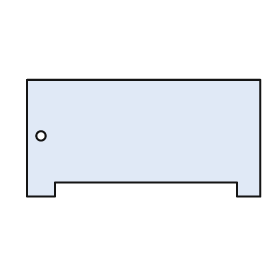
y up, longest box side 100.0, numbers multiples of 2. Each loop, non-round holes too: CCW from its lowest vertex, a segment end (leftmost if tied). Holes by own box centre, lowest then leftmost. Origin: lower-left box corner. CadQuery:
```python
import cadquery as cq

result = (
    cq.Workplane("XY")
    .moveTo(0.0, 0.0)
    .lineTo(12.0, 0.0)
    .lineTo(12.0, 6.0)
    .lineTo(90.0, 6.0)
    .lineTo(90.0, 0.0)
    .lineTo(100.0, 0.0)
    .lineTo(100.0, 50.0)
    .lineTo(0.0, 50.0)
    .close()
    .moveTo(6.0, 26.0)
    .circle(2.0)
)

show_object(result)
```